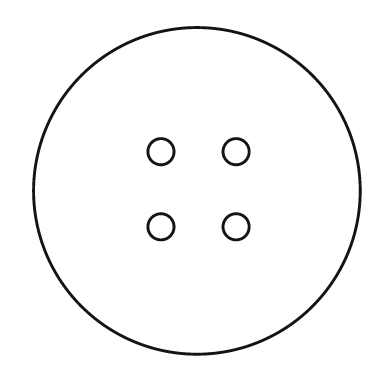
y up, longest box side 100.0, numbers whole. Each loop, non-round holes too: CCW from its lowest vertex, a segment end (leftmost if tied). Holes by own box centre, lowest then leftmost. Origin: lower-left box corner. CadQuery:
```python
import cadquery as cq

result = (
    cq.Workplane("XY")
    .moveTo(50.0, 50.0)
    .circle(50.0)
    .moveTo(39.0, 39.0)
    .circle(4.0)
    .moveTo(62.0, 39.0)
    .circle(4.0)
    .moveTo(39.0, 62.0)
    .circle(4.0)
    .moveTo(62.0, 62.0)
    .circle(4.0)
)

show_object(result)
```